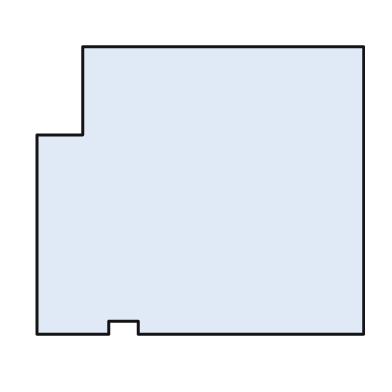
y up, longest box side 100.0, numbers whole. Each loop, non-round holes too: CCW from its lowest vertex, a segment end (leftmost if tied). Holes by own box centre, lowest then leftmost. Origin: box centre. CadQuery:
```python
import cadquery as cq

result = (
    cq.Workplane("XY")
    .moveTo(-50.0, -44.0)
    .lineTo(-28.0, -44.0)
    .lineTo(-28.0, -40.0)
    .lineTo(-19.0, -40.0)
    .lineTo(-19.0, -44.0)
    .lineTo(50.0, -44.0)
    .lineTo(50.0, 44.0)
    .lineTo(-36.0, 44.0)
    .lineTo(-36.0, 17.0)
    .lineTo(-50.0, 17.0)
    .close()
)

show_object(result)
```